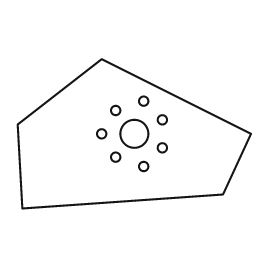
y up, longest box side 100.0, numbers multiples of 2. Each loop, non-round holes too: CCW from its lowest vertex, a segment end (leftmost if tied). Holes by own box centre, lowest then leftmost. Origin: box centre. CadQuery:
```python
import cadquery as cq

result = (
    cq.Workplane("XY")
    .moveTo(-48.0, -32.0)
    .lineTo(38.0, -26.0)
    .lineTo(50.0, 0.0)
    .lineTo(-14.0, 32.0)
    .lineTo(-50.0, 4.0)
    .close()
    .moveTo(4.0, -14.0)
    .circle(2.0)
    .moveTo(-8.0, -10.0)
    .circle(2.0)
    .moveTo(12.0, -6.0)
    .circle(2.0)
    .moveTo(-14.0, 0.0)
    .circle(2.0)
    .moveTo(0.0, 0.0)
    .circle(6.0)
    .moveTo(12.0, 6.0)
    .circle(2.0)
    .moveTo(-8.0, 10.0)
    .circle(2.0)
    .moveTo(4.0, 14.0)
    .circle(2.0)
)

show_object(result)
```